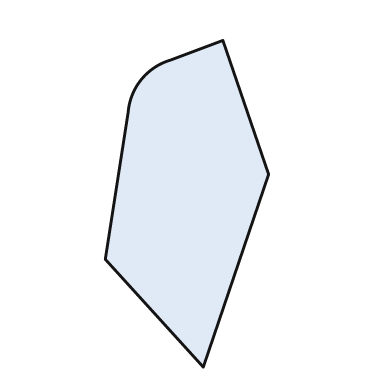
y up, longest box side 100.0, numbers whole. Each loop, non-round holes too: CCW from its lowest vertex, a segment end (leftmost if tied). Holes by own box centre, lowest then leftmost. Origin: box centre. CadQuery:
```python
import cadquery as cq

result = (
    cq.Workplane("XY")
    .moveTo(5.0, -50.0)
    .lineTo(25.0, 9.0)
    .lineTo(11.0, 50.0)
    .lineTo(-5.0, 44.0)
    .threePointArc((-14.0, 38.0), (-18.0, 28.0))
    .lineTo(-25.0, -17.0)
    .close()
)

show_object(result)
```